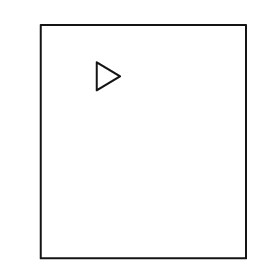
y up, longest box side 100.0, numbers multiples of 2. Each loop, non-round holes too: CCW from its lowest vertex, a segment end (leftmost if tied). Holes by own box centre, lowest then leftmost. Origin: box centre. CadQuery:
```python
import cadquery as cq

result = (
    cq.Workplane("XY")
    .moveTo(-44.0, -50.0)
    .lineTo(44.0, -50.0)
    .lineTo(44.0, 50.0)
    .lineTo(-44.0, 50.0)
    .close()
    .moveTo(-20.0, 22.0)
    .lineTo(-10.0, 28.0)
    .lineTo(-20.0, 34.0)
    .close()
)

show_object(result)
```